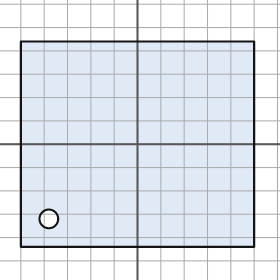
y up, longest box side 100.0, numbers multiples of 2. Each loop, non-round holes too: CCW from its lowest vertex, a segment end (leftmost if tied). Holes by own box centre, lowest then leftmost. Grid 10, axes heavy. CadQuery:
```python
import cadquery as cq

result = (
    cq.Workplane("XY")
    .moveTo(-50.0, -44.0)
    .lineTo(50.0, -44.0)
    .lineTo(50.0, 44.0)
    .lineTo(-50.0, 44.0)
    .close()
    .moveTo(-38.0, -32.0)
    .circle(4.0)
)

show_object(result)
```